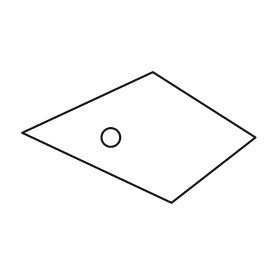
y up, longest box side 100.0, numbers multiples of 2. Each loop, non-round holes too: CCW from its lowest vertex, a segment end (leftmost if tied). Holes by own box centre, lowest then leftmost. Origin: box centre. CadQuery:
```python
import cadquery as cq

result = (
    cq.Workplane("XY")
    .moveTo(14.0, -28.0)
    .lineTo(50.0, 0.0)
    .lineTo(6.0, 28.0)
    .lineTo(-50.0, 2.0)
    .close()
    .moveTo(-12.0, 0.0)
    .circle(4.0)
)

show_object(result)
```